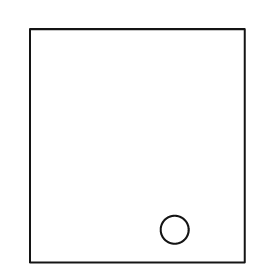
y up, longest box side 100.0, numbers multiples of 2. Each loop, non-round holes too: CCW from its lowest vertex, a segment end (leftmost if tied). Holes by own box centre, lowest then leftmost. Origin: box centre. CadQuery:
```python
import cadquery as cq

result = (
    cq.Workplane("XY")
    .moveTo(-46.0, -50.0)
    .lineTo(46.0, -50.0)
    .lineTo(46.0, 50.0)
    .lineTo(-46.0, 50.0)
    .close()
    .moveTo(16.0, -36.0)
    .circle(6.0)
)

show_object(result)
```